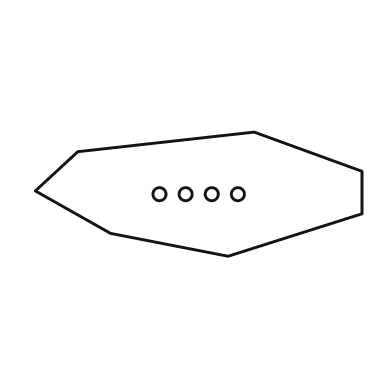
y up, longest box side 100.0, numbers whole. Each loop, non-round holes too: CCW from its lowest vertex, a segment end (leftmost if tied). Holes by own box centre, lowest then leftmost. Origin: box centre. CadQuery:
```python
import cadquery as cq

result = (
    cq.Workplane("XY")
    .moveTo(9.0, -19.0)
    .lineTo(50.0, -6.0)
    .lineTo(50.0, 7.0)
    .lineTo(17.0, 19.0)
    .lineTo(-37.0, 13.0)
    .lineTo(-50.0, 1.0)
    .lineTo(-27.0, -12.0)
    .close()
    .moveTo(-12.0, 0.0)
    .circle(2.0)
    .moveTo(-4.0, 0.0)
    .circle(2.0)
    .moveTo(4.0, 0.0)
    .circle(2.0)
    .moveTo(12.0, 0.0)
    .circle(2.0)
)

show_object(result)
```